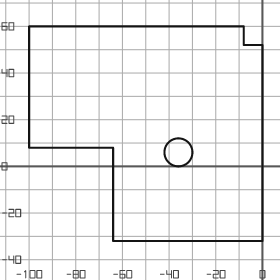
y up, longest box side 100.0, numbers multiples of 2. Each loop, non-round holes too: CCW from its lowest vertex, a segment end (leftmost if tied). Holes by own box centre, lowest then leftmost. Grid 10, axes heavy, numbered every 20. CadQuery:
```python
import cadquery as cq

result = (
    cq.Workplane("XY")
    .moveTo(-64.0, -32.0)
    .lineTo(0.0, -32.0)
    .lineTo(0.0, 52.0)
    .lineTo(-8.0, 52.0)
    .lineTo(-8.0, 60.0)
    .lineTo(-100.0, 60.0)
    .lineTo(-100.0, 8.0)
    .lineTo(-64.0, 8.0)
    .close()
    .moveTo(-36.0, 6.0)
    .circle(6.0)
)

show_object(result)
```